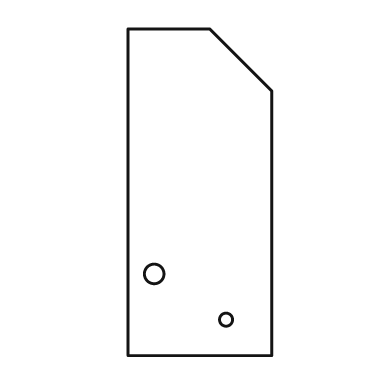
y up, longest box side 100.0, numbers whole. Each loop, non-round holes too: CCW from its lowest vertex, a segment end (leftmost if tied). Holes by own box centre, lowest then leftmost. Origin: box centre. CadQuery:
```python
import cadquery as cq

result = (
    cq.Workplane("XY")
    .moveTo(-22.0, -50.0)
    .lineTo(22.0, -50.0)
    .lineTo(22.0, 31.0)
    .lineTo(3.0, 50.0)
    .lineTo(-22.0, 50.0)
    .close()
    .moveTo(8.0, -39.0)
    .circle(2.0)
    .moveTo(-14.0, -25.0)
    .circle(3.0)
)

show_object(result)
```